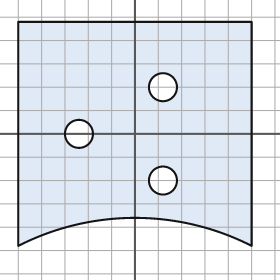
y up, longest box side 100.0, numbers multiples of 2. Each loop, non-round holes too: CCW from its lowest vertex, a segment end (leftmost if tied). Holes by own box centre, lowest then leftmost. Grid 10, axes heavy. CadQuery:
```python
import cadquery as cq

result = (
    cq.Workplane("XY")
    .moveTo(-50.0, -48.0)
    .threePointArc((0.0, -36.0), (50.0, -48.0))
    .lineTo(50.0, 48.0)
    .lineTo(-50.0, 48.0)
    .close()
    .moveTo(12.0, -20.0)
    .circle(6.0)
    .moveTo(-24.0, 0.0)
    .circle(6.0)
    .moveTo(12.0, 20.0)
    .circle(6.0)
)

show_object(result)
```